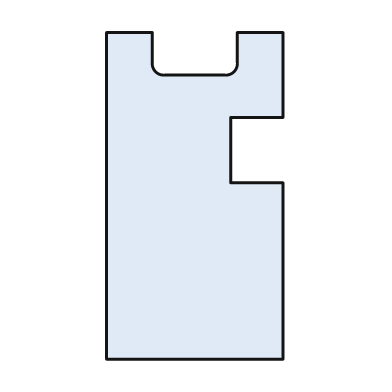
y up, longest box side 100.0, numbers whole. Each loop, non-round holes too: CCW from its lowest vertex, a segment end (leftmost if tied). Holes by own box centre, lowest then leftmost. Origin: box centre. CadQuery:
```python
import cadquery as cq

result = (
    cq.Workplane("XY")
    .moveTo(-27.0, -50.0)
    .lineTo(27.0, -50.0)
    .lineTo(27.0, 4.0)
    .lineTo(11.0, 4.0)
    .lineTo(11.0, 24.0)
    .lineTo(27.0, 24.0)
    .lineTo(27.0, 50.0)
    .lineTo(13.0, 50.0)
    .lineTo(13.0, 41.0)
    .threePointArc((12.0, 38.0), (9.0, 37.0))
    .lineTo(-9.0, 37.0)
    .threePointArc((-12.0, 38.0), (-13.0, 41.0))
    .lineTo(-13.0, 50.0)
    .lineTo(-27.0, 50.0)
    .close()
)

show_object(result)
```